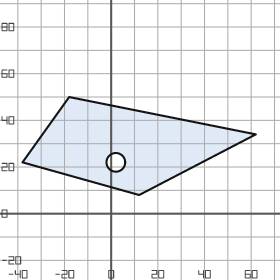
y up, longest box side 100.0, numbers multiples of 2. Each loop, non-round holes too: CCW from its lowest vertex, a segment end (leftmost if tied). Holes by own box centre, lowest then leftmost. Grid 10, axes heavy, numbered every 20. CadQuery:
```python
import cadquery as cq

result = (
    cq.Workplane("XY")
    .moveTo(12.0, 8.0)
    .lineTo(62.0, 34.0)
    .lineTo(-18.0, 50.0)
    .lineTo(-38.0, 22.0)
    .close()
    .moveTo(2.0, 22.0)
    .circle(4.0)
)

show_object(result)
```